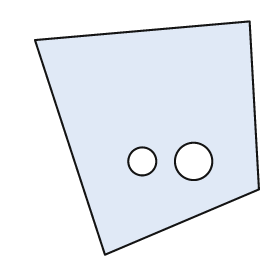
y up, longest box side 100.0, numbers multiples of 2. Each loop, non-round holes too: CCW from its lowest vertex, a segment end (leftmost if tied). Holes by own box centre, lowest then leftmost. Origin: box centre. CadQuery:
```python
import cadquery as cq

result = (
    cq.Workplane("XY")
    .moveTo(-18.0, -50.0)
    .lineTo(48.0, -22.0)
    .lineTo(44.0, 50.0)
    .lineTo(-48.0, 42.0)
    .close()
    .moveTo(-2.0, -10.0)
    .circle(6.0)
    .moveTo(20.0, -10.0)
    .circle(8.0)
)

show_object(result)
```